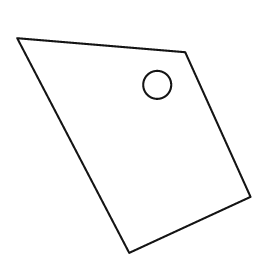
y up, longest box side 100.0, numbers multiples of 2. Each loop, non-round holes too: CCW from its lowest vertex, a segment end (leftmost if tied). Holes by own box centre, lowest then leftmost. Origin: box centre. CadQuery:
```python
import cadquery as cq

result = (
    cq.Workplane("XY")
    .moveTo(-2.0, -46.0)
    .lineTo(50.0, -22.0)
    .lineTo(22.0, 40.0)
    .lineTo(-50.0, 46.0)
    .close()
    .moveTo(10.0, 26.0)
    .circle(6.0)
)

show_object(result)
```